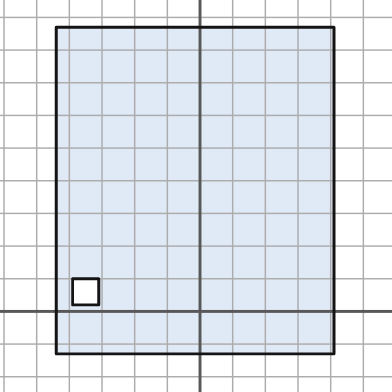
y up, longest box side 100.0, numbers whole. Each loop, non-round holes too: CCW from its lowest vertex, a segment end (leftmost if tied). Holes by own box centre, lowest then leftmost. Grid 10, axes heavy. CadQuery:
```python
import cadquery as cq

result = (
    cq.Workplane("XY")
    .moveTo(-44.0, -13.0)
    .lineTo(41.0, -13.0)
    .lineTo(41.0, 87.0)
    .lineTo(-44.0, 87.0)
    .close()
    .moveTo(-39.0, 2.0)
    .lineTo(-31.0, 2.0)
    .lineTo(-31.0, 10.0)
    .lineTo(-39.0, 10.0)
    .close()
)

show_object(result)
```